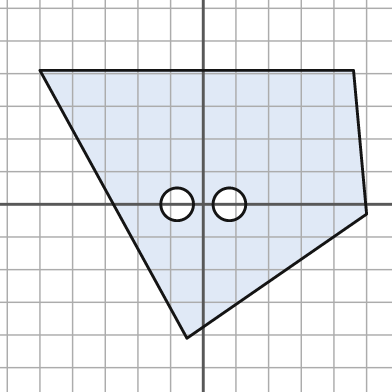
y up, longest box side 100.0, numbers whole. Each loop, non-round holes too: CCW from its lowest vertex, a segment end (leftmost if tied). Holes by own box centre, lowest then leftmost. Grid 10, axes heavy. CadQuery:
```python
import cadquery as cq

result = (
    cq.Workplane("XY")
    .moveTo(-5.0, -41.0)
    .lineTo(50.0, -3.0)
    .lineTo(46.0, 41.0)
    .lineTo(-50.0, 41.0)
    .close()
    .moveTo(-8.0, 0.0)
    .circle(5.0)
    .moveTo(8.0, 0.0)
    .circle(5.0)
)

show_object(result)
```